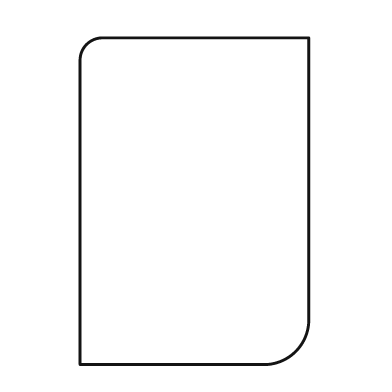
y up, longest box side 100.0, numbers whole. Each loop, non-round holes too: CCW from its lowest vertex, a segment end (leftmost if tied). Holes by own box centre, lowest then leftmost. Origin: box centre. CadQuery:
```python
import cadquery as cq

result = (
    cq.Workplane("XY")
    .moveTo(-35.0, -50.0)
    .lineTo(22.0, -50.0)
    .threePointArc((31.0, -46.0), (35.0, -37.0))
    .lineTo(35.0, 50.0)
    .lineTo(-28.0, 50.0)
    .threePointArc((-33.0, 48.0), (-35.0, 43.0))
    .close()
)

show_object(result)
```